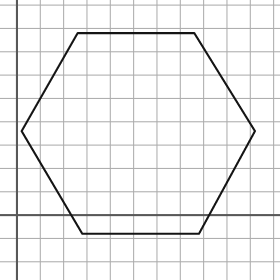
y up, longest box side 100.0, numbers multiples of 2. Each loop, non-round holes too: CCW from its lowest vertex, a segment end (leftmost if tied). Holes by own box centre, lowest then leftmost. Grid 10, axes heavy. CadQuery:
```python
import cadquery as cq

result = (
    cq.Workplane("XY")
    .moveTo(28.0, -8.0)
    .lineTo(78.0, -8.0)
    .lineTo(102.0, 36.0)
    .lineTo(76.0, 78.0)
    .lineTo(26.0, 78.0)
    .lineTo(2.0, 36.0)
    .close()
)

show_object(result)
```